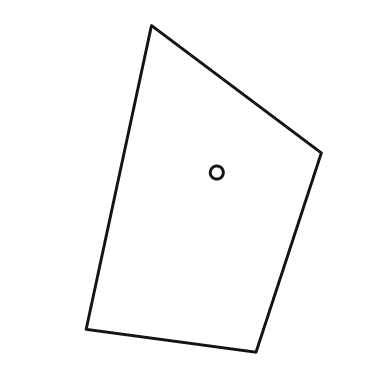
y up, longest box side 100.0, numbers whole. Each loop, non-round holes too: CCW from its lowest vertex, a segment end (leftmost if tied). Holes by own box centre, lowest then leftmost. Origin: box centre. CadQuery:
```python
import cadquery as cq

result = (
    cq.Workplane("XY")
    .moveTo(16.0, -50.0)
    .lineTo(36.0, 11.0)
    .lineTo(-16.0, 50.0)
    .lineTo(-36.0, -43.0)
    .close()
    .moveTo(4.0, 5.0)
    .circle(2.0)
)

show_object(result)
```